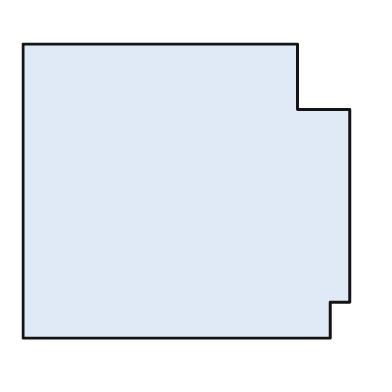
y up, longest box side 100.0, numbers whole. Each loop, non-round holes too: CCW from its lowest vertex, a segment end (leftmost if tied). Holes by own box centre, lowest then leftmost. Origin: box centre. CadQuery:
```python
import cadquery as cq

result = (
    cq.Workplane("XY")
    .moveTo(-50.0, -45.0)
    .lineTo(44.0, -45.0)
    .lineTo(44.0, -34.0)
    .lineTo(50.0, -34.0)
    .lineTo(50.0, 25.0)
    .lineTo(34.0, 25.0)
    .lineTo(34.0, 45.0)
    .lineTo(-50.0, 45.0)
    .close()
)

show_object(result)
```